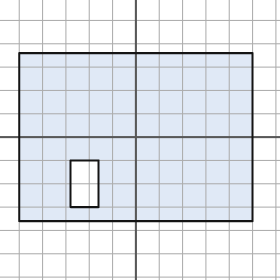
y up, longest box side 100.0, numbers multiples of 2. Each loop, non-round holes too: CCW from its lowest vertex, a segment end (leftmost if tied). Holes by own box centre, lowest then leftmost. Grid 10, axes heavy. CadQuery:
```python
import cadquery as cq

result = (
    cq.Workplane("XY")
    .moveTo(-50.0, -36.0)
    .lineTo(50.0, -36.0)
    .lineTo(50.0, 36.0)
    .lineTo(-50.0, 36.0)
    .close()
    .moveTo(-28.0, -30.0)
    .lineTo(-16.0, -30.0)
    .lineTo(-16.0, -10.0)
    .lineTo(-28.0, -10.0)
    .close()
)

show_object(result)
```